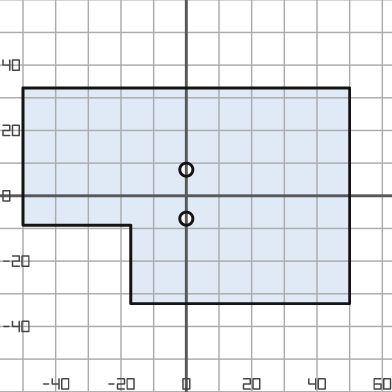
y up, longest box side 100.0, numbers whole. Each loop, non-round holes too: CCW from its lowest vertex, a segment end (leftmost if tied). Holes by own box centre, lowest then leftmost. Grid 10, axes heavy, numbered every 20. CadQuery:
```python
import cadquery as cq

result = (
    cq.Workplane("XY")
    .moveTo(-17.0, -33.0)
    .lineTo(50.0, -33.0)
    .lineTo(50.0, 33.0)
    .lineTo(-50.0, 33.0)
    .lineTo(-50.0, -9.0)
    .lineTo(-17.0, -9.0)
    .close()
    .moveTo(0.0, -7.0)
    .circle(2.0)
    .moveTo(0.0, 8.0)
    .circle(2.0)
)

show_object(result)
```